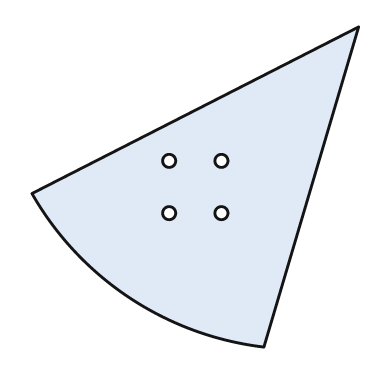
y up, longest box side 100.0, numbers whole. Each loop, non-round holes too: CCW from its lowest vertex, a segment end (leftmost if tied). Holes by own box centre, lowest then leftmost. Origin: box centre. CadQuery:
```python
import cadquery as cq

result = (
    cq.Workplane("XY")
    .moveTo(21.0, -49.0)
    .lineTo(50.0, 49.0)
    .lineTo(-50.0, -2.0)
    .threePointArc((-20.0, -34.0), (21.0, -49.0))
    .close()
    .moveTo(-8.0, -8.0)
    .circle(2.0)
    .moveTo(8.0, -8.0)
    .circle(2.0)
    .moveTo(-8.0, 8.0)
    .circle(2.0)
    .moveTo(8.0, 8.0)
    .circle(2.0)
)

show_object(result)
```